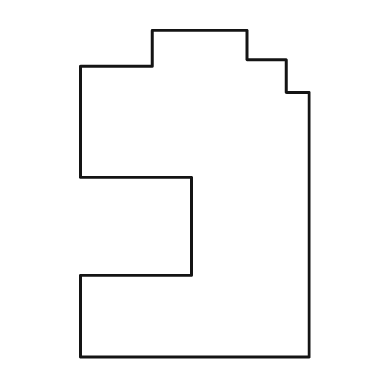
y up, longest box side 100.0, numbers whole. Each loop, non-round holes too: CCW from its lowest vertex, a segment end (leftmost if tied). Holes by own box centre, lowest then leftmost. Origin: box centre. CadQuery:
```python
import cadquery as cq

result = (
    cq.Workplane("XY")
    .moveTo(-35.0, -50.0)
    .lineTo(35.0, -50.0)
    .lineTo(35.0, 31.0)
    .lineTo(28.0, 31.0)
    .lineTo(28.0, 41.0)
    .lineTo(16.0, 41.0)
    .lineTo(16.0, 50.0)
    .lineTo(-13.0, 50.0)
    .lineTo(-13.0, 39.0)
    .lineTo(-35.0, 39.0)
    .lineTo(-35.0, 5.0)
    .lineTo(-1.0, 5.0)
    .lineTo(-1.0, -25.0)
    .lineTo(-35.0, -25.0)
    .close()
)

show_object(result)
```